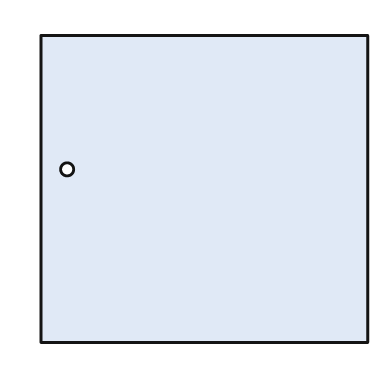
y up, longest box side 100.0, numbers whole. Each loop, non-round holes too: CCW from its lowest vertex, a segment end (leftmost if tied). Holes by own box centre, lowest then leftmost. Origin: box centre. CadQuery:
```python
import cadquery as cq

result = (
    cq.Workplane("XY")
    .moveTo(-50.0, -47.0)
    .lineTo(50.0, -47.0)
    .lineTo(50.0, 47.0)
    .lineTo(-50.0, 47.0)
    .close()
    .moveTo(-42.0, 6.0)
    .circle(2.0)
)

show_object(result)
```